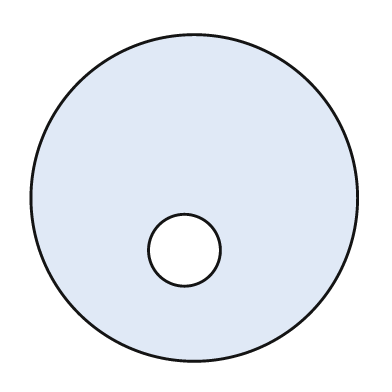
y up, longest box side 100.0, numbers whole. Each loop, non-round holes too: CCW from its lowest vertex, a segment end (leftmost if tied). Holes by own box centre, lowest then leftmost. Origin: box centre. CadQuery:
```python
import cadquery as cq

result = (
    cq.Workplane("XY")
    .moveTo(0.0, 0.0)
    .circle(50.0)
    .moveTo(-3.0, -16.0)
    .circle(11.0)
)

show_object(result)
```